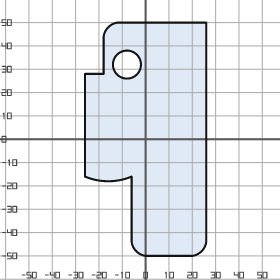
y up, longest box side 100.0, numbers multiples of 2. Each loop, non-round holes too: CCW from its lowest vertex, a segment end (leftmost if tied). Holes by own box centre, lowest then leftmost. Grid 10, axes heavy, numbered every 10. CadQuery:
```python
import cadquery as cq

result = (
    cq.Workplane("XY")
    .moveTo(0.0, -50.0)
    .lineTo(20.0, -50.0)
    .threePointArc((24.0, -48.0), (26.0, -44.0))
    .lineTo(26.0, 50.0)
    .lineTo(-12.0, 50.0)
    .threePointArc((-16.0, 48.0), (-18.0, 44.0))
    .lineTo(-18.0, 28.0)
    .lineTo(-26.0, 28.0)
    .lineTo(-26.0, -16.0)
    .threePointArc((-16.0, -18.0), (-6.0, -16.0))
    .lineTo(-6.0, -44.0)
    .threePointArc((-4.0, -48.0), (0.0, -50.0))
    .close()
    .moveTo(-8.0, 32.0)
    .circle(6.0)
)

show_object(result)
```